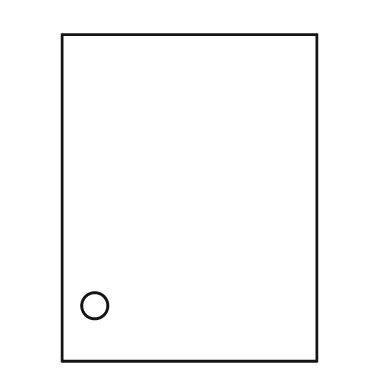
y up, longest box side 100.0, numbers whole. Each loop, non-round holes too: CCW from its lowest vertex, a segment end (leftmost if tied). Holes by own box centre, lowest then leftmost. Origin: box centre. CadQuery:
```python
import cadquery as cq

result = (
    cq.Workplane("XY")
    .moveTo(-39.0, -50.0)
    .lineTo(39.0, -50.0)
    .lineTo(39.0, 50.0)
    .lineTo(-39.0, 50.0)
    .close()
    .moveTo(-29.0, -33.0)
    .circle(4.0)
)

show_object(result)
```